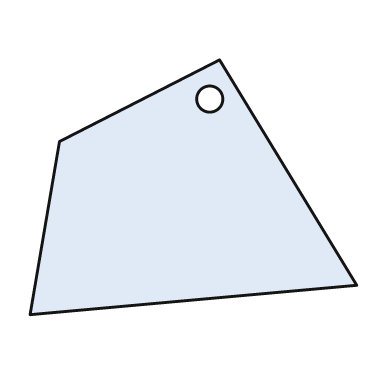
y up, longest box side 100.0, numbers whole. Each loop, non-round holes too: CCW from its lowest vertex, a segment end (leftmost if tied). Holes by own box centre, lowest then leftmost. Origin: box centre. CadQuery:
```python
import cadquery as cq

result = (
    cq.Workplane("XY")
    .moveTo(-50.0, -39.0)
    .lineTo(50.0, -30.0)
    .lineTo(8.0, 39.0)
    .lineTo(-41.0, 14.0)
    .close()
    .moveTo(5.0, 27.0)
    .circle(4.0)
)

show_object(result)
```